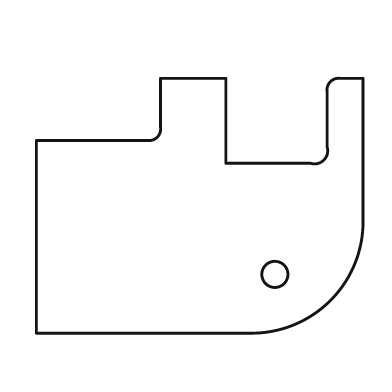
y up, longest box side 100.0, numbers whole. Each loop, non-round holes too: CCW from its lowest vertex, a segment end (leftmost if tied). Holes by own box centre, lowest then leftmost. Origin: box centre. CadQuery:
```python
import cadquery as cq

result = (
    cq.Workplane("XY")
    .moveTo(-50.0, -39.0)
    .lineTo(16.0, -39.0)
    .threePointArc((40.0, -29.0), (50.0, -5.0))
    .lineTo(50.0, 39.0)
    .lineTo(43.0, 39.0)
    .threePointArc((40.0, 38.0), (39.0, 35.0))
    .lineTo(39.0, 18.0)
    .threePointArc((38.0, 14.0), (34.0, 13.0))
    .lineTo(8.0, 13.0)
    .lineTo(8.0, 39.0)
    .lineTo(-12.0, 39.0)
    .lineTo(-12.0, 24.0)
    .threePointArc((-13.0, 21.0), (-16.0, 20.0))
    .lineTo(-50.0, 20.0)
    .close()
    .moveTo(23.0, -21.0)
    .circle(4.0)
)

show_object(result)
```